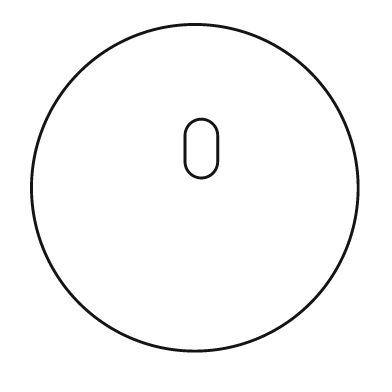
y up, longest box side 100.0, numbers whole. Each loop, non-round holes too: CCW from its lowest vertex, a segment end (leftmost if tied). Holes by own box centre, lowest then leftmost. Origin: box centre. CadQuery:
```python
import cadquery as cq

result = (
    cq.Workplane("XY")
    .moveTo(0.0, 0.0)
    .circle(50.0)
    .moveTo(-3.0, 8.0)
    .threePointArc((2.0, 3.0), (7.0, 8.0))
    .lineTo(7.0, 16.0)
    .threePointArc((2.0, 21.0), (-3.0, 16.0))
    .close()
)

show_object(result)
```